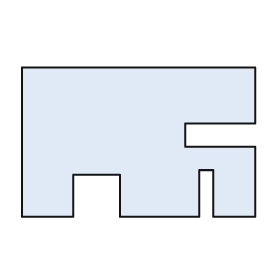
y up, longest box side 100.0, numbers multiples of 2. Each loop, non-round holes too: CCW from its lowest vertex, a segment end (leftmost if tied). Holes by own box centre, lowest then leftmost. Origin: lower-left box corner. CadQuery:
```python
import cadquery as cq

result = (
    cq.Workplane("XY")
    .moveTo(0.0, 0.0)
    .lineTo(22.0, 0.0)
    .lineTo(22.0, 18.0)
    .lineTo(42.0, 18.0)
    .lineTo(42.0, 0.0)
    .lineTo(76.0, 0.0)
    .lineTo(76.0, 20.0)
    .lineTo(82.0, 20.0)
    .lineTo(82.0, 0.0)
    .lineTo(100.0, 0.0)
    .lineTo(100.0, 30.0)
    .lineTo(70.0, 30.0)
    .lineTo(70.0, 40.0)
    .lineTo(100.0, 40.0)
    .lineTo(100.0, 64.0)
    .lineTo(0.0, 64.0)
    .close()
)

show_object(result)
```